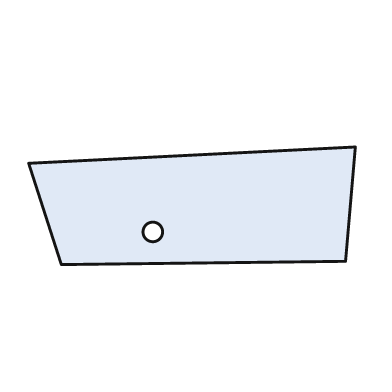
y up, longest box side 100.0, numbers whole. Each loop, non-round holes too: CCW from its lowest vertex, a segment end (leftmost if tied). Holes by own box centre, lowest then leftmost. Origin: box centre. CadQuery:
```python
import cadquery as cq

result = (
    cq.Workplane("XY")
    .moveTo(-40.0, -18.0)
    .lineTo(47.0, -17.0)
    .lineTo(50.0, 18.0)
    .lineTo(-50.0, 13.0)
    .close()
    .moveTo(-12.0, -8.0)
    .circle(3.0)
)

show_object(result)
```